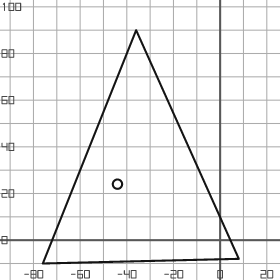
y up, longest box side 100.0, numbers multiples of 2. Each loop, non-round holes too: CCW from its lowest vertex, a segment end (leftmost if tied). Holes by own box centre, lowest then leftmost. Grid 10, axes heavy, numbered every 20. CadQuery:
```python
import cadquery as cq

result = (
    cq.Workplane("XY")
    .moveTo(-76.0, -10.0)
    .lineTo(8.0, -8.0)
    .lineTo(-36.0, 90.0)
    .close()
    .moveTo(-44.0, 24.0)
    .circle(2.0)
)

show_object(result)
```